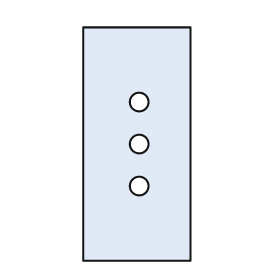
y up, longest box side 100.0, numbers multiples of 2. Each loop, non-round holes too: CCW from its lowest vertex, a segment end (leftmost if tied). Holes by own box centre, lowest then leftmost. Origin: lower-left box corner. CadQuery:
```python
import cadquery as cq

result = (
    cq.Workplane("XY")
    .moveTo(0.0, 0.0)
    .lineTo(46.0, 0.0)
    .lineTo(46.0, 100.0)
    .lineTo(0.0, 100.0)
    .close()
    .moveTo(24.0, 32.0)
    .circle(4.0)
    .moveTo(24.0, 50.0)
    .circle(4.0)
    .moveTo(24.0, 68.0)
    .circle(4.0)
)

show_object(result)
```